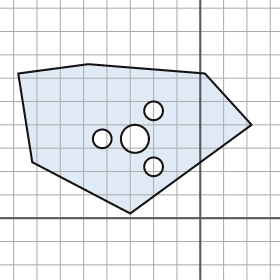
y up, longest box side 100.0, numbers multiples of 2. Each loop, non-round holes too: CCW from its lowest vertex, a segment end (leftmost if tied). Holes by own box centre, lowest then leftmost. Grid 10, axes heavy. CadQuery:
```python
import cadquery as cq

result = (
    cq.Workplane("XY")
    .moveTo(-30.0, 2.0)
    .lineTo(22.0, 40.0)
    .lineTo(2.0, 62.0)
    .lineTo(-48.0, 66.0)
    .lineTo(-78.0, 62.0)
    .lineTo(-72.0, 24.0)
    .close()
    .moveTo(-20.0, 22.0)
    .circle(4.0)
    .moveTo(-42.0, 34.0)
    .circle(4.0)
    .moveTo(-28.0, 34.0)
    .circle(6.0)
    .moveTo(-20.0, 46.0)
    .circle(4.0)
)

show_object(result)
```